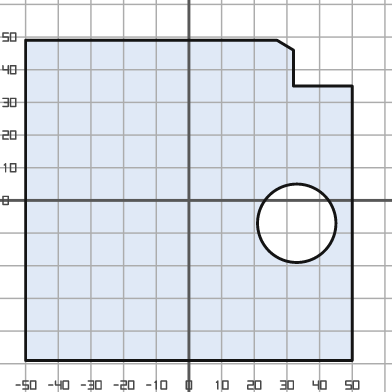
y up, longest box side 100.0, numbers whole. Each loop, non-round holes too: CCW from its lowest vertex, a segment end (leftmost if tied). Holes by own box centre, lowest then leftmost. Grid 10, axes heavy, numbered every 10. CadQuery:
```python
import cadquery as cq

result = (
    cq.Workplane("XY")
    .moveTo(-50.0, -49.0)
    .lineTo(50.0, -49.0)
    .lineTo(50.0, 35.0)
    .lineTo(32.0, 35.0)
    .lineTo(32.0, 46.0)
    .lineTo(27.0, 49.0)
    .lineTo(-50.0, 49.0)
    .close()
    .moveTo(33.0, -7.0)
    .circle(12.0)
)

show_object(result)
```